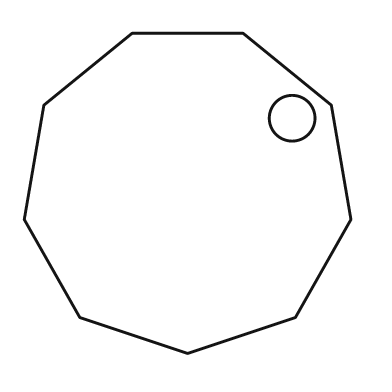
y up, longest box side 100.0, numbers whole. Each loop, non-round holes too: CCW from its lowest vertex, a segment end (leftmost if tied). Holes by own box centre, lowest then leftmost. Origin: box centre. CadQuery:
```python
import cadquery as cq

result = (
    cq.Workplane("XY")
    .moveTo(0.0, -49.0)
    .lineTo(33.0, -38.0)
    .lineTo(50.0, -8.0)
    .lineTo(44.0, 27.0)
    .lineTo(17.0, 49.0)
    .lineTo(-17.0, 49.0)
    .lineTo(-44.0, 27.0)
    .lineTo(-50.0, -8.0)
    .lineTo(-33.0, -38.0)
    .close()
    .moveTo(32.0, 23.0)
    .circle(7.0)
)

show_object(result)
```